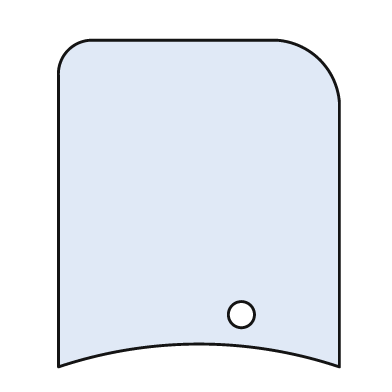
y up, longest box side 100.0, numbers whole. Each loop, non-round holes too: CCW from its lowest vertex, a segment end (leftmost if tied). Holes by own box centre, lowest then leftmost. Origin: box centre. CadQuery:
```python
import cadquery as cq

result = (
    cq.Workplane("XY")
    .moveTo(-43.0, -50.0)
    .threePointArc((0.0, -43.0), (43.0, -50.0))
    .lineTo(43.0, 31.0)
    .threePointArc((37.0, 44.0), (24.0, 50.0))
    .lineTo(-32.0, 50.0)
    .threePointArc((-40.0, 47.0), (-43.0, 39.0))
    .close()
    .moveTo(13.0, -34.0)
    .circle(4.0)
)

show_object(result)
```